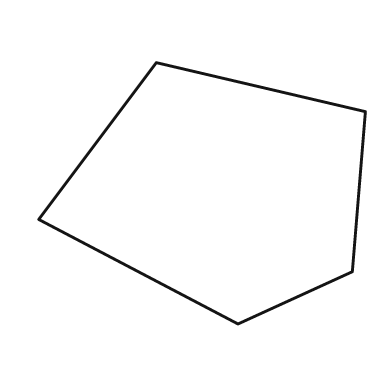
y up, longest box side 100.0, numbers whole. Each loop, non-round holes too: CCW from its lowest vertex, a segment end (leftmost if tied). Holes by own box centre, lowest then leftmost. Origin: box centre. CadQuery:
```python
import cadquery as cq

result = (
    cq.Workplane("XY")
    .moveTo(11.0, -40.0)
    .lineTo(46.0, -24.0)
    .lineTo(50.0, 25.0)
    .lineTo(-14.0, 40.0)
    .lineTo(-50.0, -8.0)
    .close()
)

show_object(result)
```